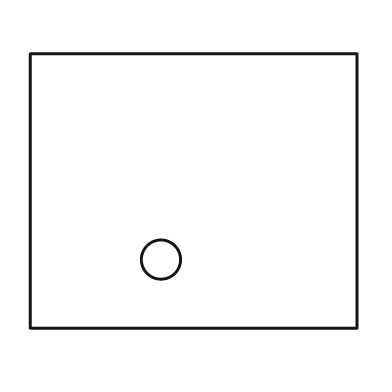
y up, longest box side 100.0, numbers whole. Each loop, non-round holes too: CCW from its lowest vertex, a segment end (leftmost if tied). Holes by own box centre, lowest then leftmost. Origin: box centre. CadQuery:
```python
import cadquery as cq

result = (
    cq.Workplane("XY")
    .moveTo(-50.0, -42.0)
    .lineTo(50.0, -42.0)
    .lineTo(50.0, 42.0)
    .lineTo(-50.0, 42.0)
    .close()
    .moveTo(-10.0, -21.0)
    .circle(6.0)
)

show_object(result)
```